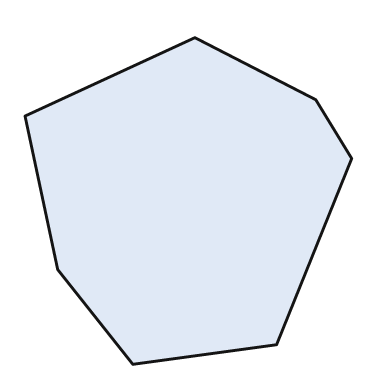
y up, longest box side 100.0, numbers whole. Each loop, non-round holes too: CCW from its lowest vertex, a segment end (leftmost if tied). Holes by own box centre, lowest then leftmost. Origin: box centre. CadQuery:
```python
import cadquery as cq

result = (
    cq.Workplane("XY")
    .moveTo(-17.0, -50.0)
    .lineTo(27.0, -44.0)
    .lineTo(50.0, 13.0)
    .lineTo(39.0, 31.0)
    .lineTo(2.0, 50.0)
    .lineTo(-50.0, 26.0)
    .lineTo(-40.0, -21.0)
    .close()
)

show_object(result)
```